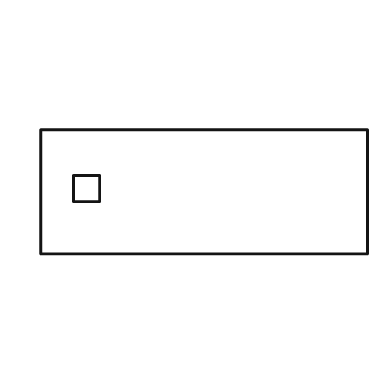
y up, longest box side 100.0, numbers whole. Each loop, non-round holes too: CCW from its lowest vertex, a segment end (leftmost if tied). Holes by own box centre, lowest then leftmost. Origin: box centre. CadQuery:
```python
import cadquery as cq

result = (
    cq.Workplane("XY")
    .moveTo(-50.0, -19.0)
    .lineTo(50.0, -19.0)
    .lineTo(50.0, 19.0)
    .lineTo(-50.0, 19.0)
    .close()
    .moveTo(-40.0, -3.0)
    .lineTo(-32.0, -3.0)
    .lineTo(-32.0, 5.0)
    .lineTo(-40.0, 5.0)
    .close()
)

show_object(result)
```